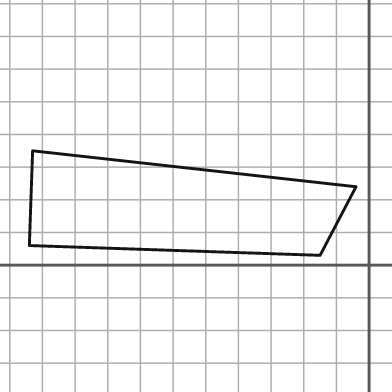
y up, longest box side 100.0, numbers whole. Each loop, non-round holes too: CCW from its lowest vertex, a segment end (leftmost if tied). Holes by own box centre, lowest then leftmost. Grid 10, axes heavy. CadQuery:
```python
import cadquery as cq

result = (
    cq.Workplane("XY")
    .moveTo(-15.0, 3.0)
    .lineTo(-4.0, 24.0)
    .lineTo(-103.0, 35.0)
    .lineTo(-104.0, 6.0)
    .close()
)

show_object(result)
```